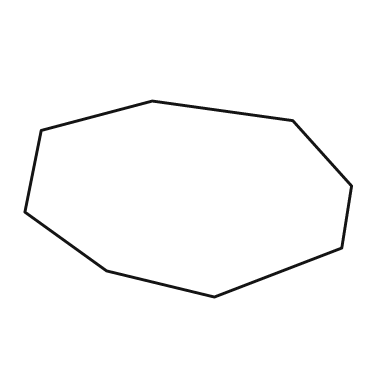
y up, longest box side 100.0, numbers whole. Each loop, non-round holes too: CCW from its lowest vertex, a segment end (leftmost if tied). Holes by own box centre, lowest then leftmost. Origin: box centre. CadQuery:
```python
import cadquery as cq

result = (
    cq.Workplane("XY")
    .moveTo(8.0, -30.0)
    .lineTo(47.0, -15.0)
    .lineTo(50.0, 4.0)
    .lineTo(32.0, 24.0)
    .lineTo(-11.0, 30.0)
    .lineTo(-45.0, 21.0)
    .lineTo(-50.0, -4.0)
    .lineTo(-25.0, -22.0)
    .close()
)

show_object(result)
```